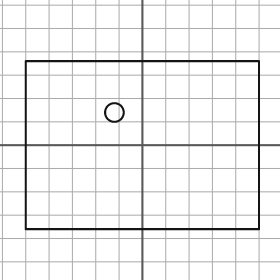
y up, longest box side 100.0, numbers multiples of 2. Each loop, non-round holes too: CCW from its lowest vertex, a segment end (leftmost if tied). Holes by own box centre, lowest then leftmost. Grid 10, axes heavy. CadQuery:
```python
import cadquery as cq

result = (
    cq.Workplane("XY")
    .moveTo(-50.0, -36.0)
    .lineTo(50.0, -36.0)
    .lineTo(50.0, 36.0)
    .lineTo(-50.0, 36.0)
    .close()
    .moveTo(-12.0, 14.0)
    .circle(4.0)
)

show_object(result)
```